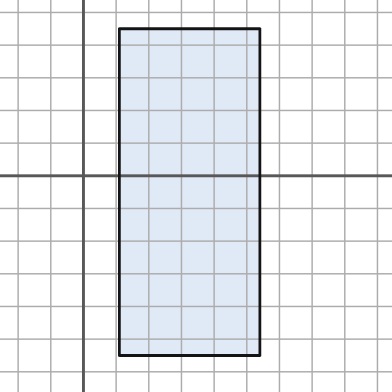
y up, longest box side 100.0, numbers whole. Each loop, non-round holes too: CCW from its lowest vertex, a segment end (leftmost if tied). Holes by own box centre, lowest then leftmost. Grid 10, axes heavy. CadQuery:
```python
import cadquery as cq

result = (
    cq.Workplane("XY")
    .moveTo(11.0, -55.0)
    .lineTo(54.0, -55.0)
    .lineTo(54.0, 45.0)
    .lineTo(11.0, 45.0)
    .close()
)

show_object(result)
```